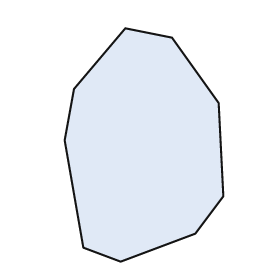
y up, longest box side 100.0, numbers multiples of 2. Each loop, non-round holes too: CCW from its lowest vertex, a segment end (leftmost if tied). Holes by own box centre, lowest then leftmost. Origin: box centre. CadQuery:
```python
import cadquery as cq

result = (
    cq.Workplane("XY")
    .moveTo(-10.0, -50.0)
    .lineTo(22.0, -38.0)
    .lineTo(34.0, -22.0)
    .lineTo(32.0, 18.0)
    .lineTo(12.0, 46.0)
    .lineTo(-8.0, 50.0)
    .lineTo(-30.0, 24.0)
    .lineTo(-34.0, 2.0)
    .lineTo(-26.0, -44.0)
    .close()
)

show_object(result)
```